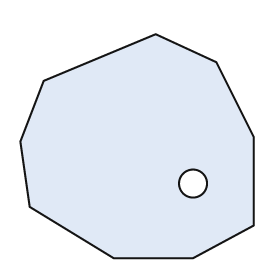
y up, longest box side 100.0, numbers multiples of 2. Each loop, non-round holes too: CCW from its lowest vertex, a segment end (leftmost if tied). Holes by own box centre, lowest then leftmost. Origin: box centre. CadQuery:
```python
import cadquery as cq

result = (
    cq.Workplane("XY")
    .moveTo(-10.0, -48.0)
    .lineTo(24.0, -48.0)
    .lineTo(50.0, -34.0)
    .lineTo(50.0, 4.0)
    .lineTo(34.0, 36.0)
    .lineTo(8.0, 48.0)
    .lineTo(-40.0, 28.0)
    .lineTo(-50.0, 2.0)
    .lineTo(-46.0, -26.0)
    .close()
    .moveTo(24.0, -16.0)
    .circle(6.0)
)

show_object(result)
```